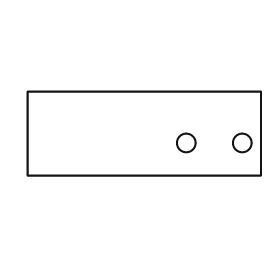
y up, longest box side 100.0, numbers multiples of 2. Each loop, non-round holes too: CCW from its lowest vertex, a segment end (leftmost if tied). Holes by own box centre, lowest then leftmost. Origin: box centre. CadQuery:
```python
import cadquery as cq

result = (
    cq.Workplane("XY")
    .moveTo(-50.0, -18.0)
    .lineTo(50.0, -18.0)
    .lineTo(50.0, 18.0)
    .lineTo(-50.0, 18.0)
    .close()
    .moveTo(18.0, -4.0)
    .circle(4.0)
    .moveTo(42.0, -4.0)
    .circle(4.0)
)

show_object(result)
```